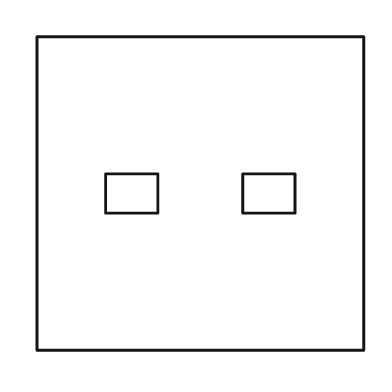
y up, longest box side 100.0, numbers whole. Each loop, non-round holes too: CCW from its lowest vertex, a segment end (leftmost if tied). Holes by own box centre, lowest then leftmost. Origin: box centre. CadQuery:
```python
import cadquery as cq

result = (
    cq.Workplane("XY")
    .moveTo(-50.0, -48.0)
    .lineTo(50.0, -48.0)
    .lineTo(50.0, 48.0)
    .lineTo(-50.0, 48.0)
    .close()
    .moveTo(-29.0, -6.0)
    .lineTo(-13.0, -6.0)
    .lineTo(-13.0, 6.0)
    .lineTo(-29.0, 6.0)
    .close()
    .moveTo(13.0, -6.0)
    .lineTo(29.0, -6.0)
    .lineTo(29.0, 6.0)
    .lineTo(13.0, 6.0)
    .close()
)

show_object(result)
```